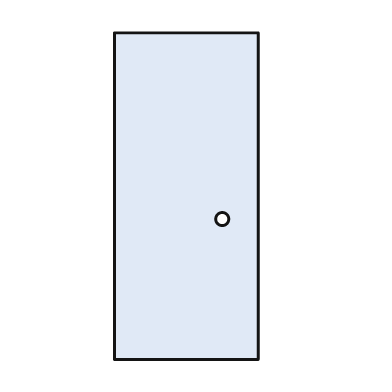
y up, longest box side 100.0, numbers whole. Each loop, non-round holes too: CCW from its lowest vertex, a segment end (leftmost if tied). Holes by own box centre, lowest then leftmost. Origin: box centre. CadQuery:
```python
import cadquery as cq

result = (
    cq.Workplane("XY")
    .moveTo(-22.0, -50.0)
    .lineTo(22.0, -50.0)
    .lineTo(22.0, 50.0)
    .lineTo(-22.0, 50.0)
    .close()
    .moveTo(11.0, -7.0)
    .circle(2.0)
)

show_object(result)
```